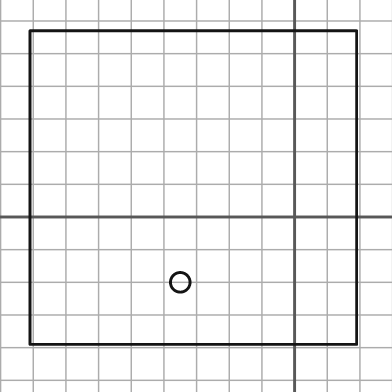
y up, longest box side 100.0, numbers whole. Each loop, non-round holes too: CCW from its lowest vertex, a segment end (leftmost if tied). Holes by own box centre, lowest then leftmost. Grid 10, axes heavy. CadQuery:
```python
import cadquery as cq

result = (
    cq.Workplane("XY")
    .moveTo(-81.0, -39.0)
    .lineTo(19.0, -39.0)
    .lineTo(19.0, 57.0)
    .lineTo(-81.0, 57.0)
    .close()
    .moveTo(-35.0, -20.0)
    .circle(3.0)
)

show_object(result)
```